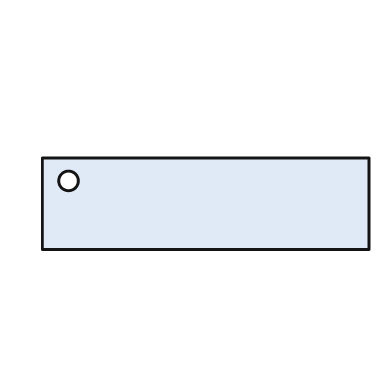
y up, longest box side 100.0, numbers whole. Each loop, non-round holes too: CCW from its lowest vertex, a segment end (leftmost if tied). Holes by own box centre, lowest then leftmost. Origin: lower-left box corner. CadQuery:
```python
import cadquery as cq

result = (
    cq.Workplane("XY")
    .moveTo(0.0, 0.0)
    .lineTo(100.0, 0.0)
    .lineTo(100.0, 28.0)
    .lineTo(0.0, 28.0)
    .close()
    .moveTo(8.0, 21.0)
    .circle(3.0)
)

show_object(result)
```